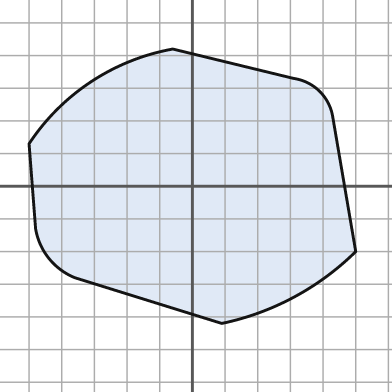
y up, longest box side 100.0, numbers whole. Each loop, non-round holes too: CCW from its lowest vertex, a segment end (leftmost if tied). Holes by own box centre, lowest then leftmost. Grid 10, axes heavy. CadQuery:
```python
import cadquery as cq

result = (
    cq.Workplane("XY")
    .moveTo(9.0, -42.0)
    .threePointArc((31.0, -34.0), (50.0, -20.0))
    .lineTo(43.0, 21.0)
    .threePointArc((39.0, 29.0), (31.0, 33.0))
    .lineTo(-6.0, 42.0)
    .threePointArc((-31.0, 32.0), (-50.0, 13.0))
    .lineTo(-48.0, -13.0)
    .threePointArc((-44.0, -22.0), (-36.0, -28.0))
    .close()
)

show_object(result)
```